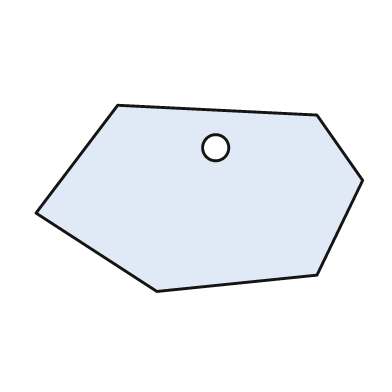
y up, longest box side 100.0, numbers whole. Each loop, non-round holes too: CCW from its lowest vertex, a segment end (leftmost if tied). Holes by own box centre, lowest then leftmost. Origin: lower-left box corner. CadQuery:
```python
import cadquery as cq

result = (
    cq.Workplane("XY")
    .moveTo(37.0, 0.0)
    .lineTo(86.0, 5.0)
    .lineTo(100.0, 34.0)
    .lineTo(86.0, 54.0)
    .lineTo(25.0, 57.0)
    .lineTo(0.0, 24.0)
    .close()
    .moveTo(55.0, 44.0)
    .circle(4.0)
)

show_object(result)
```